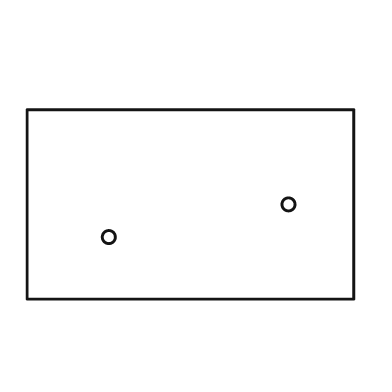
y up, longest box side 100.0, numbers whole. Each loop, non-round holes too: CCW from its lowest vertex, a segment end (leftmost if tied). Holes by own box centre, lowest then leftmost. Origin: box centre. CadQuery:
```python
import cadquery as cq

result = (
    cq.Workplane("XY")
    .moveTo(-50.0, -29.0)
    .lineTo(50.0, -29.0)
    .lineTo(50.0, 29.0)
    .lineTo(-50.0, 29.0)
    .close()
    .moveTo(-25.0, -10.0)
    .circle(2.0)
    .moveTo(30.0, 0.0)
    .circle(2.0)
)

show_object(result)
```